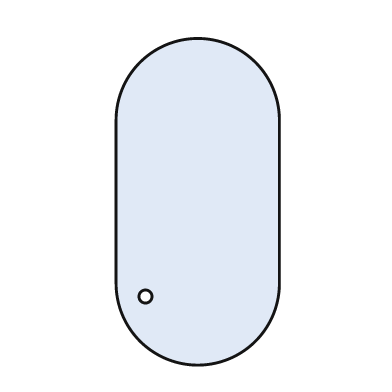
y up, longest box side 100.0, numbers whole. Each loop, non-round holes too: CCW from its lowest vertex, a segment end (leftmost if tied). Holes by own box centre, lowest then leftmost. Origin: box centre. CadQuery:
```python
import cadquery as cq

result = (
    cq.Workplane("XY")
    .moveTo(-25.0, -25.0)
    .threePointArc((0.0, -50.0), (25.0, -25.0))
    .lineTo(25.0, 25.0)
    .threePointArc((0.0, 50.0), (-25.0, 25.0))
    .close()
    .moveTo(-16.0, -29.0)
    .circle(2.0)
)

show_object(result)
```